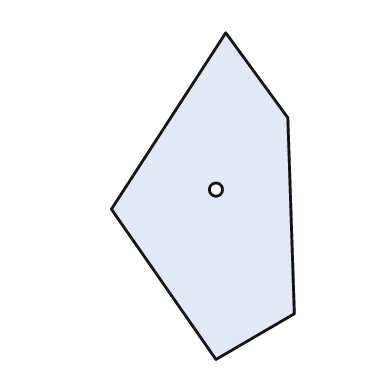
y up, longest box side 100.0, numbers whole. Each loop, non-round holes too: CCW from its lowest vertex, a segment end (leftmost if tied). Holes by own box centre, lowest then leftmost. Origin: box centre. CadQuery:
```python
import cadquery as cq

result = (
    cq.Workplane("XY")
    .moveTo(4.0, -50.0)
    .lineTo(28.0, -36.0)
    .lineTo(26.0, 24.0)
    .lineTo(7.0, 50.0)
    .lineTo(-28.0, -4.0)
    .close()
    .moveTo(4.0, 2.0)
    .circle(2.0)
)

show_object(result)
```